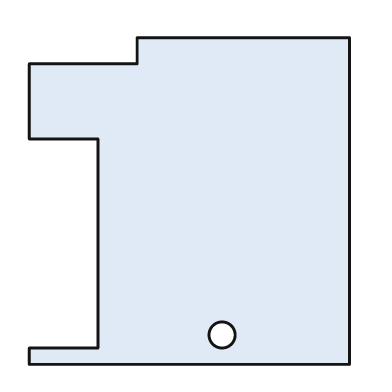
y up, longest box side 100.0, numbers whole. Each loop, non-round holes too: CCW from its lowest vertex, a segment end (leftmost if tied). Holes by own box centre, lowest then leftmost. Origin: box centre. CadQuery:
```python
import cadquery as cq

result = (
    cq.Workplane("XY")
    .moveTo(-49.0, -50.0)
    .lineTo(49.0, -50.0)
    .lineTo(49.0, 50.0)
    .lineTo(-16.0, 50.0)
    .lineTo(-16.0, 42.0)
    .lineTo(-49.0, 42.0)
    .lineTo(-49.0, 19.0)
    .lineTo(-28.0, 19.0)
    .lineTo(-28.0, -45.0)
    .lineTo(-49.0, -45.0)
    .close()
    .moveTo(10.0, -41.0)
    .circle(4.0)
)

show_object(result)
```